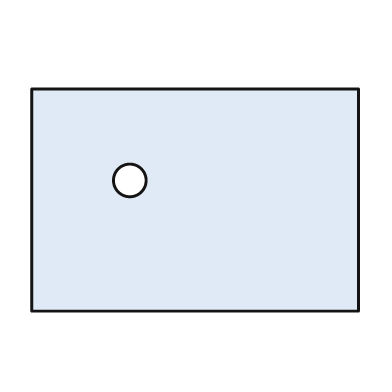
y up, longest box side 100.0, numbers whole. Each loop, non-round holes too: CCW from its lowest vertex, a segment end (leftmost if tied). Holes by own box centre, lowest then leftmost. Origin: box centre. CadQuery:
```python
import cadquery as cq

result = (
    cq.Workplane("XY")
    .moveTo(-50.0, -34.0)
    .lineTo(50.0, -34.0)
    .lineTo(50.0, 34.0)
    .lineTo(-50.0, 34.0)
    .close()
    .moveTo(-20.0, 6.0)
    .circle(5.0)
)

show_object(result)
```